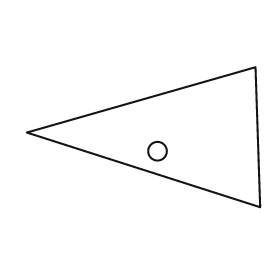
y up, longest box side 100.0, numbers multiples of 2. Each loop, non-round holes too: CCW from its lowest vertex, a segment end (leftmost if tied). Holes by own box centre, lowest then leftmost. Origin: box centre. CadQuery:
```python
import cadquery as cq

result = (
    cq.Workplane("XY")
    .moveTo(50.0, -30.0)
    .lineTo(48.0, 30.0)
    .lineTo(-50.0, 2.0)
    .close()
    .moveTo(6.0, -6.0)
    .circle(4.0)
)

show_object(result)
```